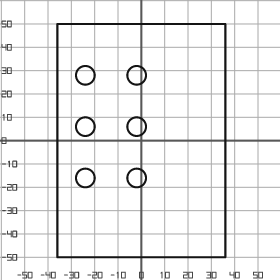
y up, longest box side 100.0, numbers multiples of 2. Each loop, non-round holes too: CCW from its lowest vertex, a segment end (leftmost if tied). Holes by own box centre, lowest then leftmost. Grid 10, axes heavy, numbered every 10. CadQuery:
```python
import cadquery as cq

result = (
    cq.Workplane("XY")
    .moveTo(-36.0, -50.0)
    .lineTo(36.0, -50.0)
    .lineTo(36.0, 50.0)
    .lineTo(-36.0, 50.0)
    .close()
    .moveTo(-24.0, -16.0)
    .circle(4.0)
    .moveTo(-2.0, -16.0)
    .circle(4.0)
    .moveTo(-24.0, 6.0)
    .circle(4.0)
    .moveTo(-2.0, 6.0)
    .circle(4.0)
    .moveTo(-24.0, 28.0)
    .circle(4.0)
    .moveTo(-2.0, 28.0)
    .circle(4.0)
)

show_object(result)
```